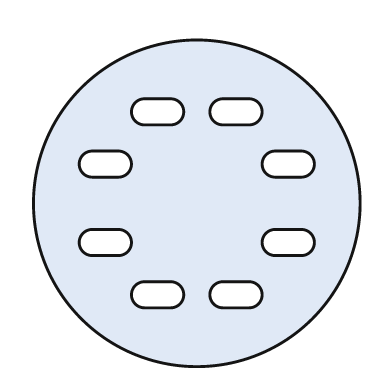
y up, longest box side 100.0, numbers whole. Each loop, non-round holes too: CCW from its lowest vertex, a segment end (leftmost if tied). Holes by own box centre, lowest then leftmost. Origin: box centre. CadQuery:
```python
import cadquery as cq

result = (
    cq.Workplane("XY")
    .moveTo(0.0, 0.0)
    .circle(50.0)
    .moveTo(-16.0, -32.0)
    .lineTo(-8.0, -32.0)
    .threePointArc((-4.0, -28.0), (-8.0, -24.0))
    .lineTo(-16.0, -24.0)
    .threePointArc((-20.0, -28.0), (-16.0, -32.0))
    .close()
    .moveTo(8.0, -32.0)
    .lineTo(16.0, -32.0)
    .threePointArc((20.0, -28.0), (16.0, -24.0))
    .lineTo(8.0, -24.0)
    .threePointArc((4.0, -28.0), (8.0, -32.0))
    .close()
    .moveTo(-32.0, -16.0)
    .lineTo(-24.0, -16.0)
    .threePointArc((-20.0, -12.0), (-24.0, -8.0))
    .lineTo(-32.0, -8.0)
    .threePointArc((-36.0, -12.0), (-32.0, -16.0))
    .close()
    .moveTo(24.0, -16.0)
    .lineTo(32.0, -16.0)
    .threePointArc((36.0, -12.0), (32.0, -8.0))
    .lineTo(24.0, -8.0)
    .threePointArc((20.0, -12.0), (24.0, -16.0))
    .close()
    .moveTo(-32.0, 8.0)
    .lineTo(-24.0, 8.0)
    .threePointArc((-20.0, 12.0), (-24.0, 16.0))
    .lineTo(-32.0, 16.0)
    .threePointArc((-36.0, 12.0), (-32.0, 8.0))
    .close()
    .moveTo(24.0, 8.0)
    .lineTo(32.0, 8.0)
    .threePointArc((36.0, 12.0), (32.0, 16.0))
    .lineTo(24.0, 16.0)
    .threePointArc((20.0, 12.0), (24.0, 8.0))
    .close()
    .moveTo(-16.0, 24.0)
    .lineTo(-8.0, 24.0)
    .threePointArc((-4.0, 28.0), (-8.0, 32.0))
    .lineTo(-16.0, 32.0)
    .threePointArc((-20.0, 28.0), (-16.0, 24.0))
    .close()
    .moveTo(8.0, 24.0)
    .lineTo(16.0, 24.0)
    .threePointArc((20.0, 28.0), (16.0, 32.0))
    .lineTo(8.0, 32.0)
    .threePointArc((4.0, 28.0), (8.0, 24.0))
    .close()
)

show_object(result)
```